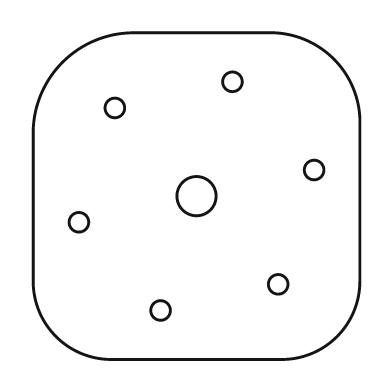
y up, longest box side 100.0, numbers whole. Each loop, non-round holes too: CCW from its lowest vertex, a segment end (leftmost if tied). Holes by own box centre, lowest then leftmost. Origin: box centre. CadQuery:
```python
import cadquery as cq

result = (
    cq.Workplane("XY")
    .moveTo(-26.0, -50.0)
    .lineTo(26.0, -50.0)
    .threePointArc((43.0, -43.0), (50.0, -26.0))
    .lineTo(50.0, 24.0)
    .threePointArc((42.0, 42.0), (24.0, 50.0))
    .lineTo(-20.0, 50.0)
    .threePointArc((-41.0, 41.0), (-50.0, 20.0))
    .lineTo(-50.0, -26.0)
    .threePointArc((-43.0, -43.0), (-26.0, -50.0))
    .close()
    .moveTo(-11.0, -35.0)
    .circle(3.0)
    .moveTo(25.0, -27.0)
    .circle(3.0)
    .moveTo(-36.0, -8.0)
    .circle(3.0)
    .moveTo(0.0, 0.0)
    .circle(6.0)
    .moveTo(36.0, 8.0)
    .circle(3.0)
    .moveTo(-25.0, 27.0)
    .circle(3.0)
    .moveTo(11.0, 35.0)
    .circle(3.0)
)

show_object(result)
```